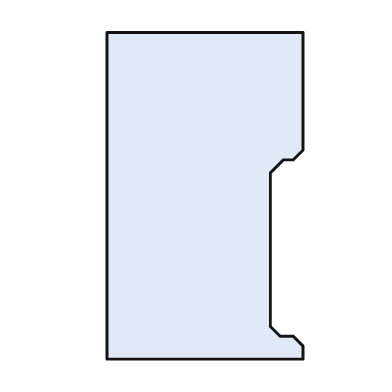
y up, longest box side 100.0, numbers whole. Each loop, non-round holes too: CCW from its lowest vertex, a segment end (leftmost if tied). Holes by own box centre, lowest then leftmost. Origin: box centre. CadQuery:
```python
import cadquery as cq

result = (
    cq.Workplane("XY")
    .moveTo(-30.0, -50.0)
    .lineTo(30.0, -50.0)
    .lineTo(30.0, -46.0)
    .lineTo(27.0, -43.0)
    .lineTo(23.0, -43.0)
    .lineTo(20.0, -40.0)
    .lineTo(20.0, 7.0)
    .lineTo(24.0, 11.0)
    .lineTo(27.0, 11.0)
    .lineTo(30.0, 14.0)
    .lineTo(30.0, 50.0)
    .lineTo(-30.0, 50.0)
    .close()
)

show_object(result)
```